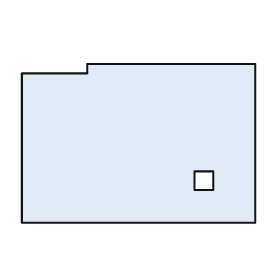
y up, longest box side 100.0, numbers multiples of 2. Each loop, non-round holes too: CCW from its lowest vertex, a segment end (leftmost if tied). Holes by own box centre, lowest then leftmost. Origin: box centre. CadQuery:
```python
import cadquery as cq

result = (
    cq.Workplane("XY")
    .moveTo(-50.0, -34.0)
    .lineTo(50.0, -34.0)
    .lineTo(50.0, 34.0)
    .lineTo(-22.0, 34.0)
    .lineTo(-22.0, 30.0)
    .lineTo(-50.0, 30.0)
    .close()
    .moveTo(24.0, -20.0)
    .lineTo(32.0, -20.0)
    .lineTo(32.0, -12.0)
    .lineTo(24.0, -12.0)
    .close()
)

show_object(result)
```